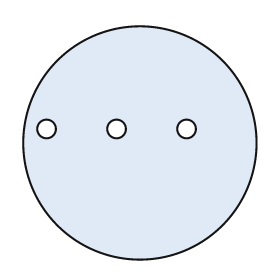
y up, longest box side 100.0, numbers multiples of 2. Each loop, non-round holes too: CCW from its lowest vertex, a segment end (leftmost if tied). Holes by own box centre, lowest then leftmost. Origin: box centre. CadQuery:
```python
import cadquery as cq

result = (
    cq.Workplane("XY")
    .moveTo(0.0, 0.0)
    .circle(50.0)
    .moveTo(-40.0, 6.0)
    .circle(4.0)
    .moveTo(-10.0, 6.0)
    .circle(4.0)
    .moveTo(20.0, 6.0)
    .circle(4.0)
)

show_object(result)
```